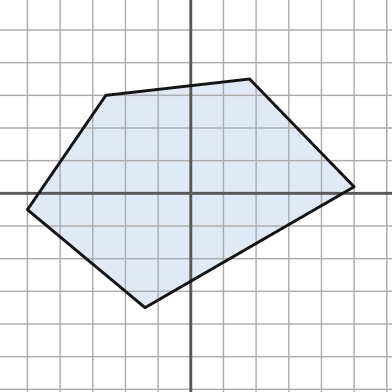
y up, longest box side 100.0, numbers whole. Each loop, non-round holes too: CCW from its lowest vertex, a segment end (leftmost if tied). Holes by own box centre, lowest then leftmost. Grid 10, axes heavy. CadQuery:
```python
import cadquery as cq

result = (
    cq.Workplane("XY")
    .moveTo(-14.0, -35.0)
    .lineTo(50.0, 2.0)
    .lineTo(18.0, 35.0)
    .lineTo(-26.0, 30.0)
    .lineTo(-50.0, -5.0)
    .close()
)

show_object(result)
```